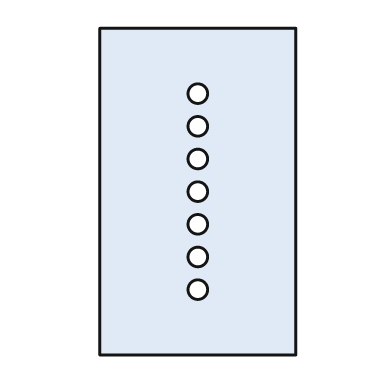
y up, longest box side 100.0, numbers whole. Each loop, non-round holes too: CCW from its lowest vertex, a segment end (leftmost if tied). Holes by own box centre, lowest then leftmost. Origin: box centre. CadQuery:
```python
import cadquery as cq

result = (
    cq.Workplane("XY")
    .moveTo(-30.0, -50.0)
    .lineTo(30.0, -50.0)
    .lineTo(30.0, 50.0)
    .lineTo(-30.0, 50.0)
    .close()
    .moveTo(0.0, -30.0)
    .circle(3.0)
    .moveTo(0.0, -20.0)
    .circle(3.0)
    .moveTo(0.0, -10.0)
    .circle(3.0)
    .moveTo(0.0, 0.0)
    .circle(3.0)
    .moveTo(0.0, 10.0)
    .circle(3.0)
    .moveTo(0.0, 20.0)
    .circle(3.0)
    .moveTo(0.0, 30.0)
    .circle(3.0)
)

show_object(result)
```